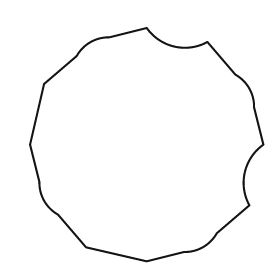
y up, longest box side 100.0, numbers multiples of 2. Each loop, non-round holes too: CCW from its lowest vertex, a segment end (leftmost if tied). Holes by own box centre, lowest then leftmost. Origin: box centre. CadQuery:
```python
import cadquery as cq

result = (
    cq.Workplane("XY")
    .moveTo(0.0, -50.0)
    .lineTo(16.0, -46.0)
    .threePointArc((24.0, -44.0), (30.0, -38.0))
    .lineTo(44.0, -26.0)
    .threePointArc((42.0, -12.0), (50.0, 0.0))
    .lineTo(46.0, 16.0)
    .threePointArc((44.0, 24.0), (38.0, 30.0))
    .lineTo(26.0, 44.0)
    .threePointArc((12.0, 42.0), (0.0, 50.0))
    .lineTo(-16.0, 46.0)
    .threePointArc((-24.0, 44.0), (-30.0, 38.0))
    .lineTo(-44.0, 26.0)
    .lineTo(-50.0, 0.0)
    .lineTo(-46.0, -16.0)
    .threePointArc((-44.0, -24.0), (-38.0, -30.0))
    .lineTo(-26.0, -44.0)
    .close()
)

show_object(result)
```